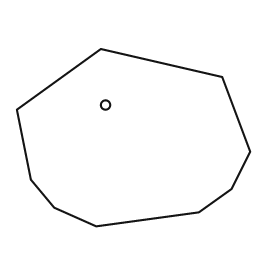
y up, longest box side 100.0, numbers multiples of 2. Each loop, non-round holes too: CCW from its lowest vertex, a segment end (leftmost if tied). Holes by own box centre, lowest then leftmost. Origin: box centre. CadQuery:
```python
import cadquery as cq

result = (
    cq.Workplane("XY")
    .moveTo(-16.0, -38.0)
    .lineTo(28.0, -32.0)
    .lineTo(42.0, -22.0)
    .lineTo(50.0, -6.0)
    .lineTo(38.0, 26.0)
    .lineTo(-14.0, 38.0)
    .lineTo(-50.0, 12.0)
    .lineTo(-44.0, -18.0)
    .lineTo(-34.0, -30.0)
    .close()
    .moveTo(-12.0, 14.0)
    .circle(2.0)
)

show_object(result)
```